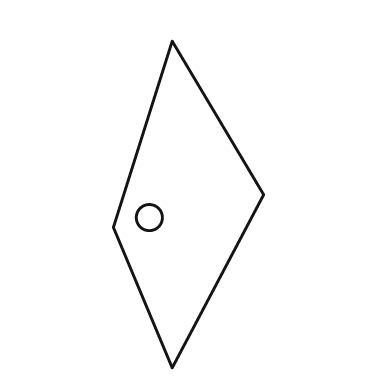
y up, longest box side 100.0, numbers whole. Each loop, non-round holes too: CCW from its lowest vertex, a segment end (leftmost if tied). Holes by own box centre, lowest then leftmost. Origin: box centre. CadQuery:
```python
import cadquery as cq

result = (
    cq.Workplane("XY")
    .moveTo(-5.0, -50.0)
    .lineTo(23.0, 3.0)
    .lineTo(-5.0, 50.0)
    .lineTo(-23.0, -7.0)
    .close()
    .moveTo(-12.0, -4.0)
    .circle(4.0)
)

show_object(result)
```